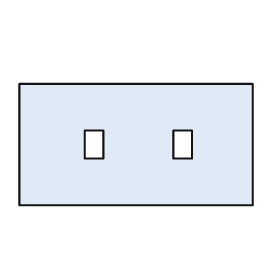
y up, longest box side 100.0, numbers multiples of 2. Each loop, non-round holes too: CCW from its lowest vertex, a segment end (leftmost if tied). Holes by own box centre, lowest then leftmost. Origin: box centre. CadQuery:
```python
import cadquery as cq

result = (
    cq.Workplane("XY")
    .moveTo(-50.0, -26.0)
    .lineTo(50.0, -26.0)
    .lineTo(50.0, 26.0)
    .lineTo(-50.0, 26.0)
    .close()
    .moveTo(-22.0, -6.0)
    .lineTo(-14.0, -6.0)
    .lineTo(-14.0, 6.0)
    .lineTo(-22.0, 6.0)
    .close()
    .moveTo(16.0, -6.0)
    .lineTo(24.0, -6.0)
    .lineTo(24.0, 6.0)
    .lineTo(16.0, 6.0)
    .close()
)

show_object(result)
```